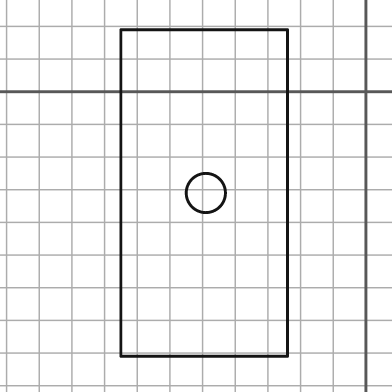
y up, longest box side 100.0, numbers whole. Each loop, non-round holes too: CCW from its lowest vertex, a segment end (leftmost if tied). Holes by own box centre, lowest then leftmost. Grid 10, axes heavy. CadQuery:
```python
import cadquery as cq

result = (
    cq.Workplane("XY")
    .moveTo(-75.0, -81.0)
    .lineTo(-24.0, -81.0)
    .lineTo(-24.0, 19.0)
    .lineTo(-75.0, 19.0)
    .close()
    .moveTo(-49.0, -31.0)
    .circle(6.0)
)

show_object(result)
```